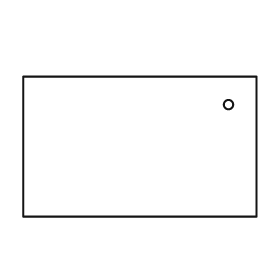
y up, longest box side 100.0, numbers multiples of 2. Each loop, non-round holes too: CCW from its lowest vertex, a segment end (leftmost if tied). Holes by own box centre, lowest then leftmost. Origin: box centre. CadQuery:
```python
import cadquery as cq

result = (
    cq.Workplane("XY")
    .moveTo(-50.0, -30.0)
    .lineTo(50.0, -30.0)
    .lineTo(50.0, 30.0)
    .lineTo(-50.0, 30.0)
    .close()
    .moveTo(38.0, 18.0)
    .circle(2.0)
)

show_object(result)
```